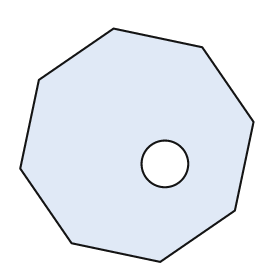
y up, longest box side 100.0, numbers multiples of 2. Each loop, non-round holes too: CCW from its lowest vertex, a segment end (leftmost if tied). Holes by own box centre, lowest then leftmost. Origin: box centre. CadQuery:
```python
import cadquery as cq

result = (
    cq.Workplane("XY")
    .moveTo(10.0, -50.0)
    .lineTo(42.0, -28.0)
    .lineTo(50.0, 10.0)
    .lineTo(28.0, 42.0)
    .lineTo(-10.0, 50.0)
    .lineTo(-42.0, 28.0)
    .lineTo(-50.0, -10.0)
    .lineTo(-28.0, -42.0)
    .close()
    .moveTo(12.0, -8.0)
    .circle(10.0)
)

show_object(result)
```